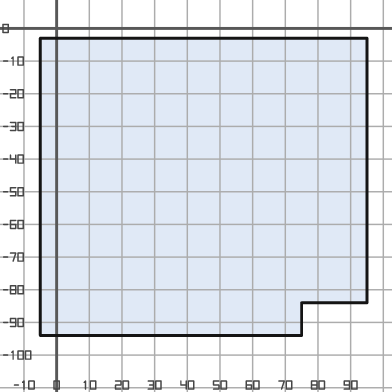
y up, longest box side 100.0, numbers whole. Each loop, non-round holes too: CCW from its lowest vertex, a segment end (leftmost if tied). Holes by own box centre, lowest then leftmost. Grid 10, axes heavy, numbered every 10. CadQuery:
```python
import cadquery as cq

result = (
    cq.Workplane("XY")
    .moveTo(-5.0, -94.0)
    .lineTo(75.0, -94.0)
    .lineTo(75.0, -84.0)
    .lineTo(95.0, -84.0)
    .lineTo(95.0, -3.0)
    .lineTo(-5.0, -3.0)
    .close()
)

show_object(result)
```